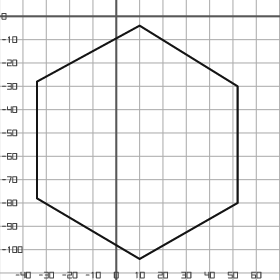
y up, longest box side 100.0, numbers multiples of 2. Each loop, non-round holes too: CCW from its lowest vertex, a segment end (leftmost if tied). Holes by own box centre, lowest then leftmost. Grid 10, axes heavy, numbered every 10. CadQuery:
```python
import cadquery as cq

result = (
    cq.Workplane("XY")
    .moveTo(10.0, -104.0)
    .lineTo(52.0, -80.0)
    .lineTo(52.0, -30.0)
    .lineTo(10.0, -4.0)
    .lineTo(-34.0, -28.0)
    .lineTo(-34.0, -78.0)
    .close()
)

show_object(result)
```